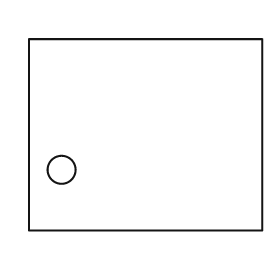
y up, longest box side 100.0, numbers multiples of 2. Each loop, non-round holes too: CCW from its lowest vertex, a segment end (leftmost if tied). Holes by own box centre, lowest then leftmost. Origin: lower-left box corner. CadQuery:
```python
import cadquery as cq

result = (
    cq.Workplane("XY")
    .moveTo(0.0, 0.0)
    .lineTo(100.0, 0.0)
    .lineTo(100.0, 82.0)
    .lineTo(0.0, 82.0)
    .close()
    .moveTo(14.0, 26.0)
    .circle(6.0)
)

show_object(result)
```